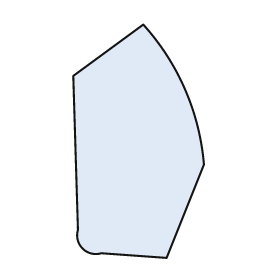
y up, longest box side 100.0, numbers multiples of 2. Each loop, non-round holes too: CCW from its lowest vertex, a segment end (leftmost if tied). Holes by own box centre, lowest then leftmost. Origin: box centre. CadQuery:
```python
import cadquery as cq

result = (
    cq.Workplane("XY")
    .moveTo(12.0, -50.0)
    .lineTo(28.0, -10.0)
    .threePointArc((20.0, 22.0), (2.0, 50.0))
    .lineTo(-28.0, 28.0)
    .lineTo(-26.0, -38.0)
    .threePointArc((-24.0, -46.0), (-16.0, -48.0))
    .close()
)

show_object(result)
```